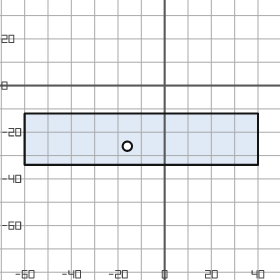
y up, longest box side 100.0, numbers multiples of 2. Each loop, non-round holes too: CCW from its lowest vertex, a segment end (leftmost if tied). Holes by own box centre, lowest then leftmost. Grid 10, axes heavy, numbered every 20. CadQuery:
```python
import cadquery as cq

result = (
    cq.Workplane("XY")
    .moveTo(-60.0, -34.0)
    .lineTo(40.0, -34.0)
    .lineTo(40.0, -12.0)
    .lineTo(-60.0, -12.0)
    .close()
    .moveTo(-16.0, -26.0)
    .circle(2.0)
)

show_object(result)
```